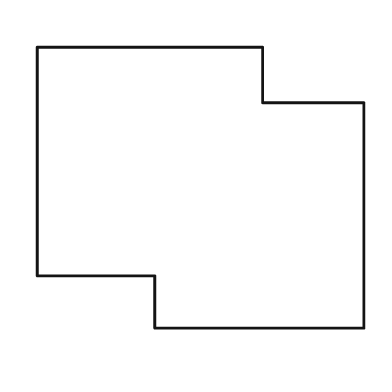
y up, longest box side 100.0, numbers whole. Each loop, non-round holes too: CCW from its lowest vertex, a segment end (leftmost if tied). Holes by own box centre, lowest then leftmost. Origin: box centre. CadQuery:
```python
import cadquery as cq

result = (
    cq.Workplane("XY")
    .moveTo(-14.0, -43.0)
    .lineTo(50.0, -43.0)
    .lineTo(50.0, 26.0)
    .lineTo(19.0, 26.0)
    .lineTo(19.0, 43.0)
    .lineTo(-50.0, 43.0)
    .lineTo(-50.0, -27.0)
    .lineTo(-14.0, -27.0)
    .close()
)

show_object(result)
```